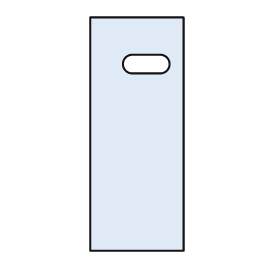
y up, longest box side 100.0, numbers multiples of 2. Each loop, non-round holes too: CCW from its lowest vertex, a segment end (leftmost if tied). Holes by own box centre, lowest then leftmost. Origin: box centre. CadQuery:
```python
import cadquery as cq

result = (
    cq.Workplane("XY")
    .moveTo(-20.0, -50.0)
    .lineTo(20.0, -50.0)
    .lineTo(20.0, 50.0)
    .lineTo(-20.0, 50.0)
    .close()
    .moveTo(-2.0, 26.0)
    .lineTo(10.0, 26.0)
    .threePointArc((14.0, 30.0), (10.0, 34.0))
    .lineTo(-2.0, 34.0)
    .threePointArc((-6.0, 30.0), (-2.0, 26.0))
    .close()
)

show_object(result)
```